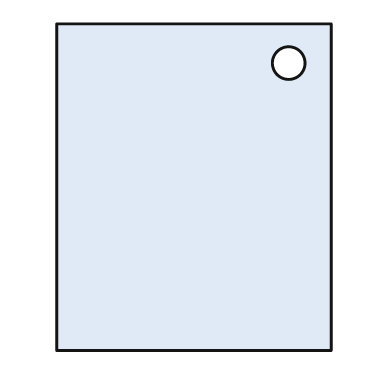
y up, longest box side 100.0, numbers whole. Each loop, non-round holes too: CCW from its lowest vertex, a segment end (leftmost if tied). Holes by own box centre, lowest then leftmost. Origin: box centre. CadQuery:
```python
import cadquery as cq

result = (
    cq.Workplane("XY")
    .moveTo(-42.0, -50.0)
    .lineTo(42.0, -50.0)
    .lineTo(42.0, 50.0)
    .lineTo(-42.0, 50.0)
    .close()
    .moveTo(29.0, 38.0)
    .circle(5.0)
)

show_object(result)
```